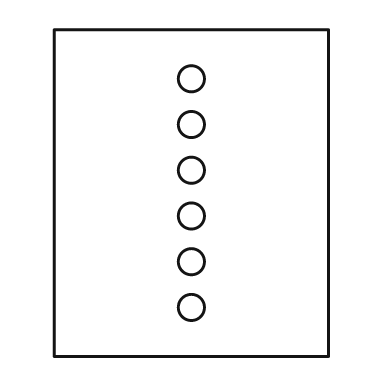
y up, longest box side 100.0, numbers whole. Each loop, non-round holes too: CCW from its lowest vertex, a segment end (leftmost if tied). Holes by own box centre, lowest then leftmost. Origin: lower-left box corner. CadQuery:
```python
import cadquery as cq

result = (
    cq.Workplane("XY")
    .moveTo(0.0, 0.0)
    .lineTo(84.0, 0.0)
    .lineTo(84.0, 100.0)
    .lineTo(0.0, 100.0)
    .close()
    .moveTo(42.0, 15.0)
    .circle(4.0)
    .moveTo(42.0, 29.0)
    .circle(4.0)
    .moveTo(42.0, 43.0)
    .circle(4.0)
    .moveTo(42.0, 57.0)
    .circle(4.0)
    .moveTo(42.0, 71.0)
    .circle(4.0)
    .moveTo(42.0, 85.0)
    .circle(4.0)
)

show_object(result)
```